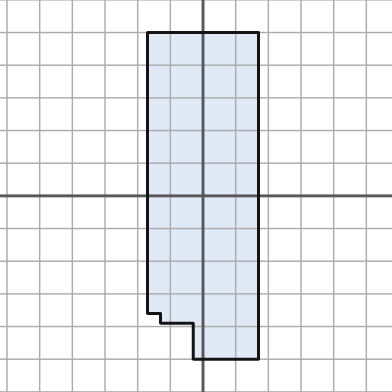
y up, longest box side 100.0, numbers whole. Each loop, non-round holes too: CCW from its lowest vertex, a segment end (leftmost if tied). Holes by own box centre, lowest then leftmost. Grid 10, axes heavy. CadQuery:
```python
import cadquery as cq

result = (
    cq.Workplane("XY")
    .moveTo(-3.0, -50.0)
    .lineTo(17.0, -50.0)
    .lineTo(17.0, 50.0)
    .lineTo(-17.0, 50.0)
    .lineTo(-17.0, -36.0)
    .lineTo(-13.0, -36.0)
    .lineTo(-13.0, -39.0)
    .lineTo(-3.0, -39.0)
    .close()
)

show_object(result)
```